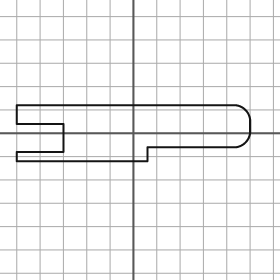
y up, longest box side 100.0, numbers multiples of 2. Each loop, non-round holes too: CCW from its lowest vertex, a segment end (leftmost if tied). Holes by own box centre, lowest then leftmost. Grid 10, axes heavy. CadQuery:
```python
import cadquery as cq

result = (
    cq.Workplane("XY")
    .moveTo(-50.0, -12.0)
    .lineTo(6.0, -12.0)
    .lineTo(6.0, -6.0)
    .lineTo(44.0, -6.0)
    .threePointArc((48.0, -4.0), (50.0, 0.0))
    .lineTo(50.0, 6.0)
    .threePointArc((48.0, 10.0), (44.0, 12.0))
    .lineTo(-50.0, 12.0)
    .lineTo(-50.0, 4.0)
    .lineTo(-30.0, 4.0)
    .lineTo(-30.0, -8.0)
    .lineTo(-50.0, -8.0)
    .close()
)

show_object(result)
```